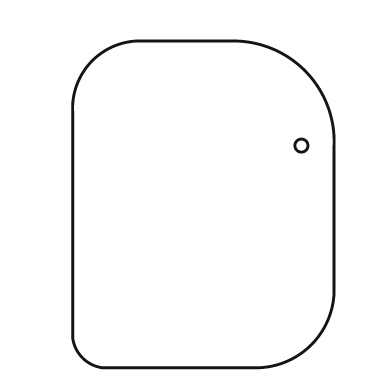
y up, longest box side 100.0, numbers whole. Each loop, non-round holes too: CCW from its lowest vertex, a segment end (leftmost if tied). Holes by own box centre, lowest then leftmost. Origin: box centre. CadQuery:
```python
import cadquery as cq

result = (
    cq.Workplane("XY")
    .moveTo(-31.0, -50.0)
    .lineTo(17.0, -50.0)
    .threePointArc((33.0, -43.0), (40.0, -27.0))
    .lineTo(40.0, 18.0)
    .threePointArc((31.0, 41.0), (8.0, 50.0))
    .lineTo(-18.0, 50.0)
    .threePointArc((-34.0, 44.0), (-40.0, 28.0))
    .lineTo(-40.0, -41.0)
    .threePointArc((-37.0, -47.0), (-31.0, -50.0))
    .close()
    .moveTo(30.0, 18.0)
    .circle(2.0)
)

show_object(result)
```